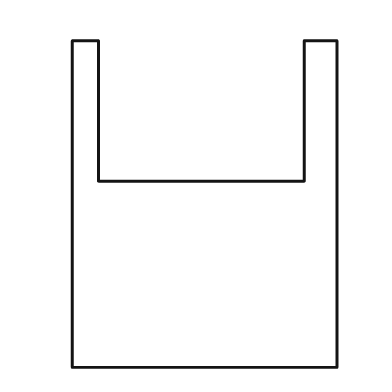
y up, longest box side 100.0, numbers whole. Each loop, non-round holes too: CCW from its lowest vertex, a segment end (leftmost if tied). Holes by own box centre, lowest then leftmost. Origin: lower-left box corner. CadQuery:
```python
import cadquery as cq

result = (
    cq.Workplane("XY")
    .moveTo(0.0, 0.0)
    .lineTo(81.0, 0.0)
    .lineTo(81.0, 100.0)
    .lineTo(71.0, 100.0)
    .lineTo(71.0, 57.0)
    .lineTo(8.0, 57.0)
    .lineTo(8.0, 100.0)
    .lineTo(0.0, 100.0)
    .close()
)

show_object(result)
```